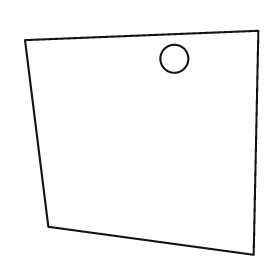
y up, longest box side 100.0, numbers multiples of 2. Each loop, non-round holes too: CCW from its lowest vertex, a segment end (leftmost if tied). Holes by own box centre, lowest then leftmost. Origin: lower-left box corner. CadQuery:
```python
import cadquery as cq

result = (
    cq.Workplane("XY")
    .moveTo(98.0, 0.0)
    .lineTo(100.0, 96.0)
    .lineTo(0.0, 92.0)
    .lineTo(10.0, 12.0)
    .close()
    .moveTo(64.0, 84.0)
    .circle(6.0)
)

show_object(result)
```